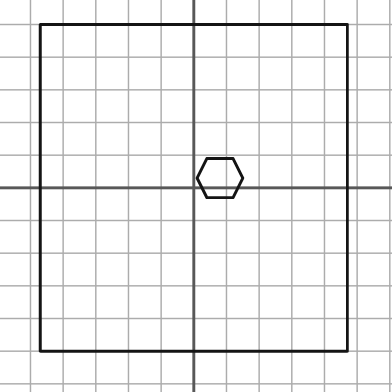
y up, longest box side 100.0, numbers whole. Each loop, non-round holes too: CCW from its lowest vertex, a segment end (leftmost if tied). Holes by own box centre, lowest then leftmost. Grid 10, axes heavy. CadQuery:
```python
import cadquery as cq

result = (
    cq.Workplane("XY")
    .moveTo(-47.0, -50.0)
    .lineTo(47.0, -50.0)
    .lineTo(47.0, 50.0)
    .lineTo(-47.0, 50.0)
    .close()
    .moveTo(4.0, -3.0)
    .lineTo(12.0, -3.0)
    .lineTo(15.0, 3.0)
    .lineTo(12.0, 9.0)
    .lineTo(4.0, 9.0)
    .lineTo(1.0, 3.0)
    .close()
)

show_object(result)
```